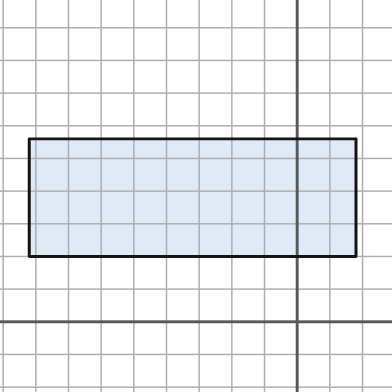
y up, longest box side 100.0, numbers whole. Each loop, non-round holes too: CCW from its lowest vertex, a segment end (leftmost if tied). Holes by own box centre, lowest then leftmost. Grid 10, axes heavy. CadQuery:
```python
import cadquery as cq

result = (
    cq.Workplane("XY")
    .moveTo(-82.0, 20.0)
    .lineTo(18.0, 20.0)
    .lineTo(18.0, 56.0)
    .lineTo(-82.0, 56.0)
    .close()
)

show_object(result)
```